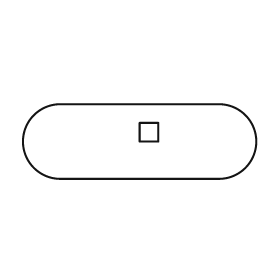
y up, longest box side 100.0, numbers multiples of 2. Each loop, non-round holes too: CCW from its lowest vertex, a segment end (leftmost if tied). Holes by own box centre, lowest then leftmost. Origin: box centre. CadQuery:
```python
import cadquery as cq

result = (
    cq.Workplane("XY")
    .moveTo(-34.0, -16.0)
    .lineTo(34.0, -16.0)
    .threePointArc((50.0, 0.0), (34.0, 16.0))
    .lineTo(-34.0, 16.0)
    .threePointArc((-50.0, 0.0), (-34.0, -16.0))
    .close()
    .moveTo(0.0, 0.0)
    .lineTo(8.0, 0.0)
    .lineTo(8.0, 8.0)
    .lineTo(0.0, 8.0)
    .close()
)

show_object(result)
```